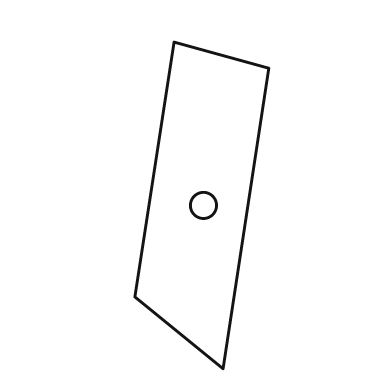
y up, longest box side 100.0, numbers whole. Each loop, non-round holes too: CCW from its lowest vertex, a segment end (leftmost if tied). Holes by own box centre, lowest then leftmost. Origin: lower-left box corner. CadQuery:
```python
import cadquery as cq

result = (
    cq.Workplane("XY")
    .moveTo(27.0, 0.0)
    .lineTo(41.0, 92.0)
    .lineTo(12.0, 100.0)
    .lineTo(0.0, 22.0)
    .close()
    .moveTo(21.0, 50.0)
    .circle(4.0)
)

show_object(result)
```